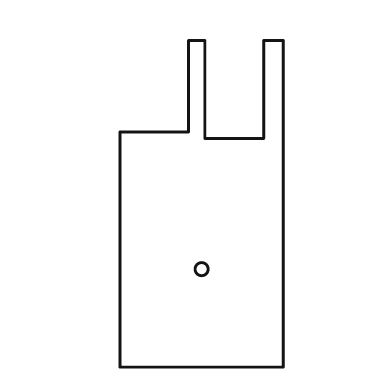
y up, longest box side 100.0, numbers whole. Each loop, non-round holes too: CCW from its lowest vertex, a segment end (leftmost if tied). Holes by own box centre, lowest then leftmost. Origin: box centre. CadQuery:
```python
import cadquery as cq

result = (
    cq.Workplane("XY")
    .moveTo(-25.0, -50.0)
    .lineTo(25.0, -50.0)
    .lineTo(25.0, 50.0)
    .lineTo(19.0, 50.0)
    .lineTo(19.0, 20.0)
    .lineTo(1.0, 20.0)
    .lineTo(1.0, 50.0)
    .lineTo(-4.0, 50.0)
    .lineTo(-4.0, 22.0)
    .lineTo(-25.0, 22.0)
    .close()
    .moveTo(0.0, -20.0)
    .circle(2.0)
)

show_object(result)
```